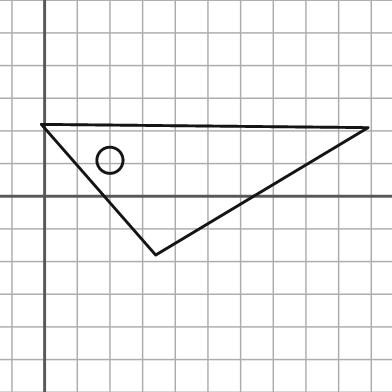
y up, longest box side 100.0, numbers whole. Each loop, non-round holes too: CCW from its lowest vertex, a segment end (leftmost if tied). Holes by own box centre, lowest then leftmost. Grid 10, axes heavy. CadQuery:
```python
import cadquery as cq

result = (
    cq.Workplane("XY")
    .moveTo(34.0, -18.0)
    .lineTo(99.0, 21.0)
    .lineTo(-1.0, 22.0)
    .close()
    .moveTo(20.0, 11.0)
    .circle(4.0)
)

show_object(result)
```